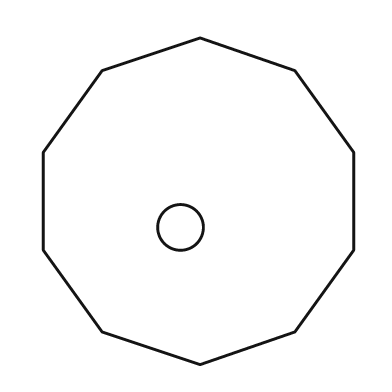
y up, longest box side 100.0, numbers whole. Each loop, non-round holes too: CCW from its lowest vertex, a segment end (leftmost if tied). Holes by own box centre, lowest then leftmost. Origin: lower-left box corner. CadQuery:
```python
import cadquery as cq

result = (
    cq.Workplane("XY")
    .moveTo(48.0, 0.0)
    .lineTo(77.0, 10.0)
    .lineTo(95.0, 35.0)
    .lineTo(95.0, 65.0)
    .lineTo(77.0, 90.0)
    .lineTo(48.0, 100.0)
    .lineTo(18.0, 90.0)
    .lineTo(0.0, 65.0)
    .lineTo(0.0, 35.0)
    .lineTo(18.0, 10.0)
    .close()
    .moveTo(42.0, 42.0)
    .circle(7.0)
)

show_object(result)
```